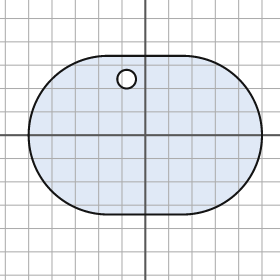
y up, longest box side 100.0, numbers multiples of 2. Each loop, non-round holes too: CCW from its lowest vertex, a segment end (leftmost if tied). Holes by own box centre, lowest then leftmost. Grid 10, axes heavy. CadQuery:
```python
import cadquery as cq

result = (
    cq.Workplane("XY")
    .moveTo(-16.0, -34.0)
    .lineTo(16.0, -34.0)
    .threePointArc((50.0, 0.0), (16.0, 34.0))
    .lineTo(-16.0, 34.0)
    .threePointArc((-50.0, 0.0), (-16.0, -34.0))
    .close()
    .moveTo(-8.0, 24.0)
    .circle(4.0)
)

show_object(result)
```